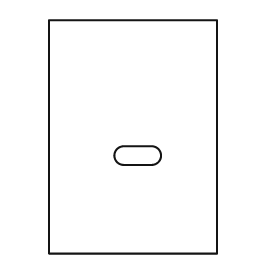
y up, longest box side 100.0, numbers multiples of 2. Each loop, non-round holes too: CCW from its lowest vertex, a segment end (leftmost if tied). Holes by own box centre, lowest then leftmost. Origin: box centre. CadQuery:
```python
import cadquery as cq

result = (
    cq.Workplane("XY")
    .moveTo(-36.0, -50.0)
    .lineTo(36.0, -50.0)
    .lineTo(36.0, 50.0)
    .lineTo(-36.0, 50.0)
    .close()
    .moveTo(-4.0, -12.0)
    .lineTo(8.0, -12.0)
    .threePointArc((12.0, -8.0), (8.0, -4.0))
    .lineTo(-4.0, -4.0)
    .threePointArc((-8.0, -8.0), (-4.0, -12.0))
    .close()
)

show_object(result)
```